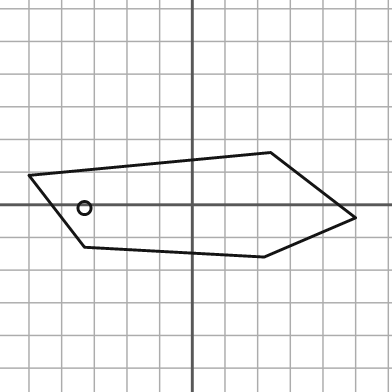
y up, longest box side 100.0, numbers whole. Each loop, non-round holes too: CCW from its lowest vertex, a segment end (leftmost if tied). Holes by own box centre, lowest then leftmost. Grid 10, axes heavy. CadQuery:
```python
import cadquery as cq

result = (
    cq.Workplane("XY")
    .moveTo(22.0, -16.0)
    .lineTo(50.0, -4.0)
    .lineTo(24.0, 16.0)
    .lineTo(-50.0, 9.0)
    .lineTo(-33.0, -13.0)
    .close()
    .moveTo(-33.0, -1.0)
    .circle(2.0)
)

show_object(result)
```